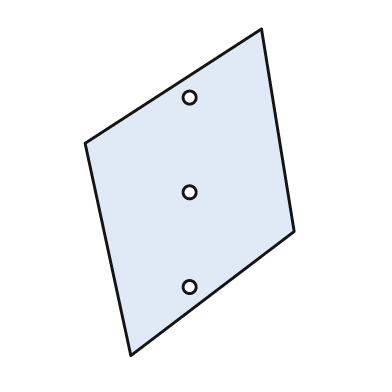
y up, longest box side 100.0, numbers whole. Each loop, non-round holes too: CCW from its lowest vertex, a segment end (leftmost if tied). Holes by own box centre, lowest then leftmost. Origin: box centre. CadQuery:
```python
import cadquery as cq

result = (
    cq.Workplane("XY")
    .moveTo(-18.0, -50.0)
    .lineTo(32.0, -12.0)
    .lineTo(22.0, 50.0)
    .lineTo(-32.0, 15.0)
    .close()
    .moveTo(0.0, -29.0)
    .circle(2.0)
    .moveTo(0.0, 0.0)
    .circle(2.0)
    .moveTo(0.0, 29.0)
    .circle(2.0)
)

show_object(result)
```